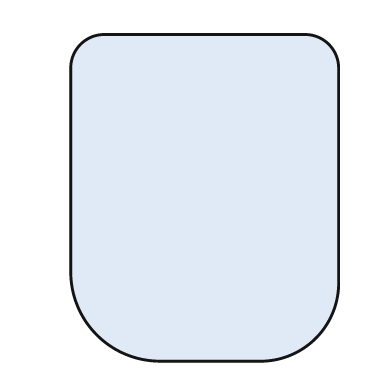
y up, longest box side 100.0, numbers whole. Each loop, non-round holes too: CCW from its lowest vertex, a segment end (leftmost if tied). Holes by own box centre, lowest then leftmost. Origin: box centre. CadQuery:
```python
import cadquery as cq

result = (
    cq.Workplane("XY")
    .moveTo(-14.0, -50.0)
    .lineTo(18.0, -50.0)
    .threePointArc((34.0, -43.0), (41.0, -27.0))
    .lineTo(41.0, 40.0)
    .threePointArc((38.0, 47.0), (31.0, 50.0))
    .lineTo(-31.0, 50.0)
    .threePointArc((-38.0, 47.0), (-41.0, 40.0))
    .lineTo(-41.0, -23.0)
    .threePointArc((-33.0, -42.0), (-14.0, -50.0))
    .close()
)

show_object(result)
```